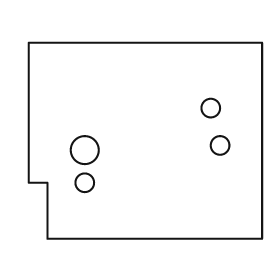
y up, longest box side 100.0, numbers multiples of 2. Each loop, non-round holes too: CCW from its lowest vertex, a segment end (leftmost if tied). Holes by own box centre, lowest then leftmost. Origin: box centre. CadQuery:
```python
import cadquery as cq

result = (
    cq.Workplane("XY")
    .moveTo(-42.0, -42.0)
    .lineTo(50.0, -42.0)
    .lineTo(50.0, 42.0)
    .lineTo(-50.0, 42.0)
    .lineTo(-50.0, -18.0)
    .lineTo(-42.0, -18.0)
    .close()
    .moveTo(-26.0, -18.0)
    .circle(4.0)
    .moveTo(-26.0, -4.0)
    .circle(6.0)
    .moveTo(32.0, -2.0)
    .circle(4.0)
    .moveTo(28.0, 14.0)
    .circle(4.0)
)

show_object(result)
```